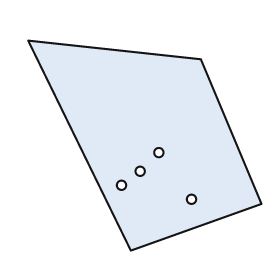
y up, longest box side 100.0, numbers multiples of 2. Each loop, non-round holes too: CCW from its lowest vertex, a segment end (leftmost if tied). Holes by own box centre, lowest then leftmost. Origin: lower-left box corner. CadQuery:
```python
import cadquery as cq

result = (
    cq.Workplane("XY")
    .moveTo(44.0, 0.0)
    .lineTo(100.0, 20.0)
    .lineTo(74.0, 82.0)
    .lineTo(0.0, 90.0)
    .close()
    .moveTo(70.0, 22.0)
    .circle(2.0)
    .moveTo(40.0, 28.0)
    .circle(2.0)
    .moveTo(48.0, 34.0)
    .circle(2.0)
    .moveTo(56.0, 42.0)
    .circle(2.0)
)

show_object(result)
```